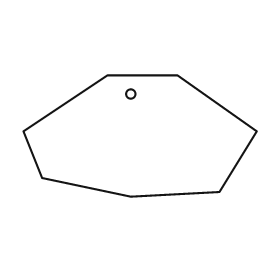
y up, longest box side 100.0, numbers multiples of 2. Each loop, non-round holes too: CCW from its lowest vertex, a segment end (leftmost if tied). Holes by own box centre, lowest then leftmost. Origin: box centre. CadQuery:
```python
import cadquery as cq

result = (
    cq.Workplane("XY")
    .moveTo(-4.0, -26.0)
    .lineTo(34.0, -24.0)
    .lineTo(50.0, 2.0)
    .lineTo(16.0, 26.0)
    .lineTo(-14.0, 26.0)
    .lineTo(-50.0, 2.0)
    .lineTo(-42.0, -18.0)
    .close()
    .moveTo(-4.0, 18.0)
    .circle(2.0)
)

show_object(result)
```